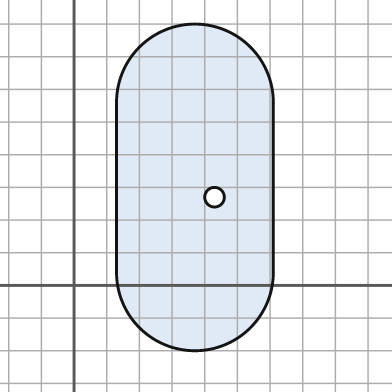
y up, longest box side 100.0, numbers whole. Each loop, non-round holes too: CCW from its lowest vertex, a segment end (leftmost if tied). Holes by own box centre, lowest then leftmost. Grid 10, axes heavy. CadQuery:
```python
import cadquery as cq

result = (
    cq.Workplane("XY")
    .moveTo(13.0, 4.0)
    .threePointArc((37.0, -20.0), (61.0, 4.0))
    .lineTo(61.0, 56.0)
    .threePointArc((37.0, 80.0), (13.0, 56.0))
    .close()
    .moveTo(43.0, 27.0)
    .circle(3.0)
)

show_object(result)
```